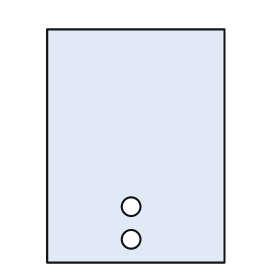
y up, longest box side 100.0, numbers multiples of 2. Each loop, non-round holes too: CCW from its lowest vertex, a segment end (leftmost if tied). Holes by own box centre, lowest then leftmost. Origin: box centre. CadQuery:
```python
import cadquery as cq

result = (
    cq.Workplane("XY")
    .moveTo(-38.0, -50.0)
    .lineTo(38.0, -50.0)
    .lineTo(38.0, 50.0)
    .lineTo(-38.0, 50.0)
    .close()
    .moveTo(-2.0, -40.0)
    .circle(4.0)
    .moveTo(-2.0, -26.0)
    .circle(4.0)
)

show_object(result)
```